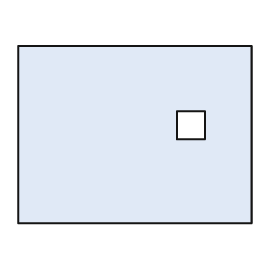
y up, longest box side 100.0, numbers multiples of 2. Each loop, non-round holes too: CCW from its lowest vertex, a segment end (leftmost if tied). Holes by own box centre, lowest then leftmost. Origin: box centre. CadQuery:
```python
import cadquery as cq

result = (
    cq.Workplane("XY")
    .moveTo(-50.0, -38.0)
    .lineTo(50.0, -38.0)
    .lineTo(50.0, 38.0)
    .lineTo(-50.0, 38.0)
    .close()
    .moveTo(18.0, -2.0)
    .lineTo(30.0, -2.0)
    .lineTo(30.0, 10.0)
    .lineTo(18.0, 10.0)
    .close()
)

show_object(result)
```